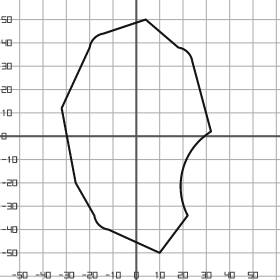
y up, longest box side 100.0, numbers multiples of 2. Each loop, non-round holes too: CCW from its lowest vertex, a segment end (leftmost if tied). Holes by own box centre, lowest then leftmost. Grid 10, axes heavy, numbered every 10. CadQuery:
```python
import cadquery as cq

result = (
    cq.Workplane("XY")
    .moveTo(10.0, -50.0)
    .lineTo(22.0, -34.0)
    .threePointArc((20.0, -14.0), (32.0, 2.0))
    .lineTo(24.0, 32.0)
    .threePointArc((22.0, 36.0), (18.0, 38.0))
    .lineTo(4.0, 50.0)
    .lineTo(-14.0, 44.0)
    .threePointArc((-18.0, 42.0), (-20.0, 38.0))
    .lineTo(-32.0, 12.0)
    .lineTo(-26.0, -20.0)
    .lineTo(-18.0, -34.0)
    .threePointArc((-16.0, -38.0), (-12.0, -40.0))
    .close()
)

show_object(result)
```